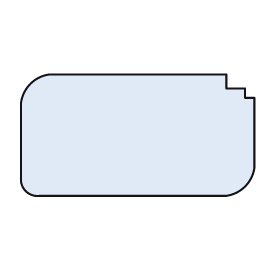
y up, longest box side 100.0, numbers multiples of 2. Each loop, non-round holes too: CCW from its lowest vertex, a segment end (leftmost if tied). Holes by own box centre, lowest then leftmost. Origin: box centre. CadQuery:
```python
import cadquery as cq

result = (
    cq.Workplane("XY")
    .moveTo(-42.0, -26.0)
    .lineTo(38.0, -26.0)
    .threePointArc((46.0, -22.0), (50.0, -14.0))
    .lineTo(50.0, 16.0)
    .lineTo(46.0, 16.0)
    .lineTo(46.0, 20.0)
    .lineTo(38.0, 20.0)
    .lineTo(38.0, 26.0)
    .lineTo(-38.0, 26.0)
    .threePointArc((-46.0, 22.0), (-50.0, 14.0))
    .lineTo(-50.0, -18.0)
    .threePointArc((-48.0, -24.0), (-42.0, -26.0))
    .close()
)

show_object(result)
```